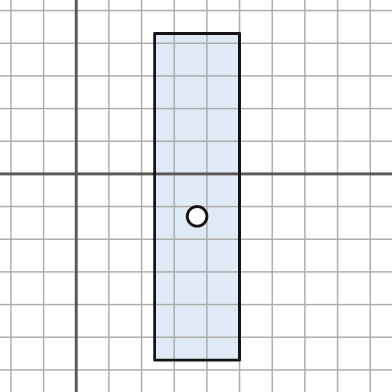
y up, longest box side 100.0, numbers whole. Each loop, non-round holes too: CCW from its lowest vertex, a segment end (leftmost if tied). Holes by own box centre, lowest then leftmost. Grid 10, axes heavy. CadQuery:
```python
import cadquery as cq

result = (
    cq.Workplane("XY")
    .moveTo(24.0, -57.0)
    .lineTo(50.0, -57.0)
    .lineTo(50.0, 43.0)
    .lineTo(24.0, 43.0)
    .close()
    .moveTo(37.0, -13.0)
    .circle(3.0)
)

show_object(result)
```